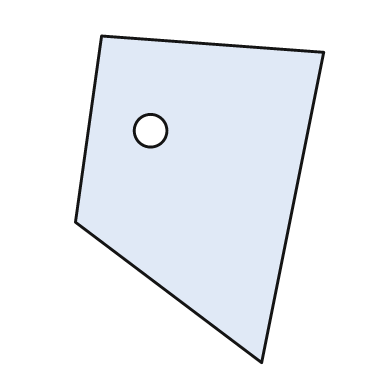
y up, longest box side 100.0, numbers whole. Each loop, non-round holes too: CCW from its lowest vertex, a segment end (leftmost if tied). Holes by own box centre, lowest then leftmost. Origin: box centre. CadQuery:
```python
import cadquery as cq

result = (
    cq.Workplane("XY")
    .moveTo(19.0, -50.0)
    .lineTo(38.0, 45.0)
    .lineTo(-30.0, 50.0)
    .lineTo(-38.0, -7.0)
    .close()
    .moveTo(-15.0, 21.0)
    .circle(5.0)
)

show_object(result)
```